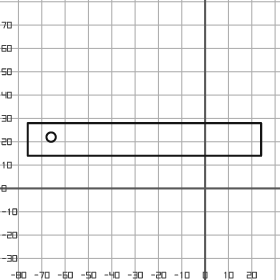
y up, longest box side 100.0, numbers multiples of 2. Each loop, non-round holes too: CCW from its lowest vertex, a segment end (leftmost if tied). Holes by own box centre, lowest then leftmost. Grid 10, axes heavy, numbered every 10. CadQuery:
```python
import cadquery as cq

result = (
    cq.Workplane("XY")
    .moveTo(-76.0, 14.0)
    .lineTo(24.0, 14.0)
    .lineTo(24.0, 28.0)
    .lineTo(-76.0, 28.0)
    .close()
    .moveTo(-66.0, 22.0)
    .circle(2.0)
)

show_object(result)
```